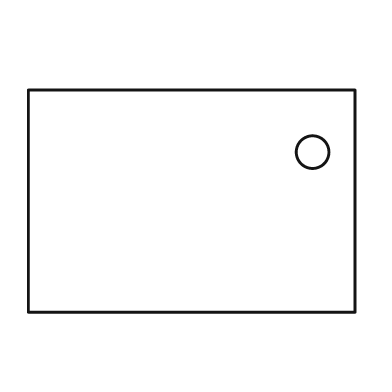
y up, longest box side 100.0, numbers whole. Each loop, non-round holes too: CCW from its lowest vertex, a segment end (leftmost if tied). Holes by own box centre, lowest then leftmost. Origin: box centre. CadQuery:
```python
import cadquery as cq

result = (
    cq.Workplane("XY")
    .moveTo(-50.0, -34.0)
    .lineTo(50.0, -34.0)
    .lineTo(50.0, 34.0)
    .lineTo(-50.0, 34.0)
    .close()
    .moveTo(37.0, 15.0)
    .circle(5.0)
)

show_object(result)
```